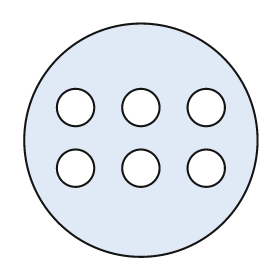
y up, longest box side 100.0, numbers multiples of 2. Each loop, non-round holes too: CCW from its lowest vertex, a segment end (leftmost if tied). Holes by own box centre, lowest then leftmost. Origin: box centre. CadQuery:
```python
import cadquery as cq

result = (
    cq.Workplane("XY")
    .moveTo(0.0, 0.0)
    .circle(50.0)
    .moveTo(-28.0, -12.0)
    .circle(8.0)
    .moveTo(0.0, -12.0)
    .circle(8.0)
    .moveTo(28.0, -12.0)
    .circle(8.0)
    .moveTo(-28.0, 14.0)
    .circle(8.0)
    .moveTo(0.0, 14.0)
    .circle(8.0)
    .moveTo(28.0, 14.0)
    .circle(8.0)
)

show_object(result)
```